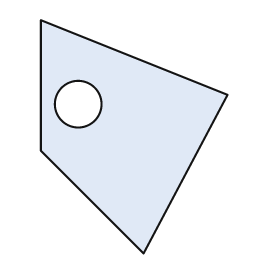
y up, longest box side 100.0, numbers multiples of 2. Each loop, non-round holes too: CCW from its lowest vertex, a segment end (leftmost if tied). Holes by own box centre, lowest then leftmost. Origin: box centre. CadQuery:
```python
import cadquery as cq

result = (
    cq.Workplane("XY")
    .moveTo(4.0, -50.0)
    .lineTo(40.0, 18.0)
    .lineTo(-40.0, 50.0)
    .lineTo(-40.0, -6.0)
    .close()
    .moveTo(-24.0, 14.0)
    .circle(10.0)
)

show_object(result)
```